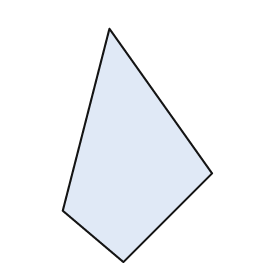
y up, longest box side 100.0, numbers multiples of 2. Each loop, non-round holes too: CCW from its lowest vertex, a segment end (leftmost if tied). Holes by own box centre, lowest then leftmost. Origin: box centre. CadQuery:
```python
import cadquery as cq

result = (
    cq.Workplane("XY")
    .moveTo(-6.0, -50.0)
    .lineTo(32.0, -12.0)
    .lineTo(-12.0, 50.0)
    .lineTo(-32.0, -28.0)
    .close()
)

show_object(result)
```